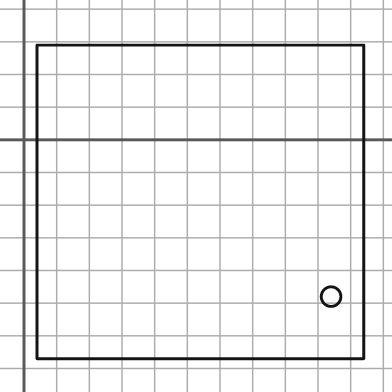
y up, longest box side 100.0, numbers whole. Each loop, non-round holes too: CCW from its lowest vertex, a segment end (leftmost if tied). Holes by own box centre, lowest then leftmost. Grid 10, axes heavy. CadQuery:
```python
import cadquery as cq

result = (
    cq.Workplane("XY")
    .moveTo(4.0, -67.0)
    .lineTo(104.0, -67.0)
    .lineTo(104.0, 29.0)
    .lineTo(4.0, 29.0)
    .close()
    .moveTo(94.0, -48.0)
    .circle(3.0)
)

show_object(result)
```